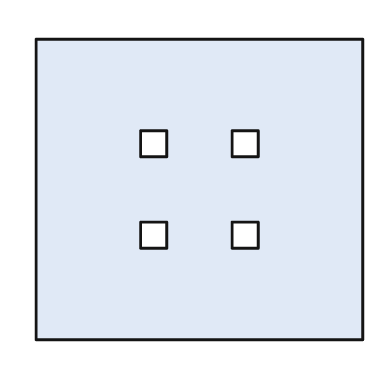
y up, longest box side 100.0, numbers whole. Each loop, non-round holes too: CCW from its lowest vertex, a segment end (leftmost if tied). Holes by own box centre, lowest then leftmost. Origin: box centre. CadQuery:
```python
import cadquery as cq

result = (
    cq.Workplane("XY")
    .moveTo(-50.0, -46.0)
    .lineTo(50.0, -46.0)
    .lineTo(50.0, 46.0)
    .lineTo(-50.0, 46.0)
    .close()
    .moveTo(-18.0, -18.0)
    .lineTo(-10.0, -18.0)
    .lineTo(-10.0, -10.0)
    .lineTo(-18.0, -10.0)
    .close()
    .moveTo(10.0, -18.0)
    .lineTo(18.0, -18.0)
    .lineTo(18.0, -10.0)
    .lineTo(10.0, -10.0)
    .close()
    .moveTo(-18.0, 10.0)
    .lineTo(-10.0, 10.0)
    .lineTo(-10.0, 18.0)
    .lineTo(-18.0, 18.0)
    .close()
    .moveTo(10.0, 10.0)
    .lineTo(18.0, 10.0)
    .lineTo(18.0, 18.0)
    .lineTo(10.0, 18.0)
    .close()
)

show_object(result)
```